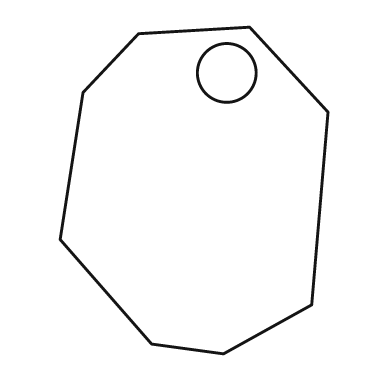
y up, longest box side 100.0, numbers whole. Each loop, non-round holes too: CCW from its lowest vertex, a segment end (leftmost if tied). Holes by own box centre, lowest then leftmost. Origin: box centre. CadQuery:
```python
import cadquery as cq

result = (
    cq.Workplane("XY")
    .moveTo(9.0, -50.0)
    .lineTo(36.0, -35.0)
    .lineTo(41.0, 24.0)
    .lineTo(17.0, 50.0)
    .lineTo(-17.0, 48.0)
    .lineTo(-34.0, 30.0)
    .lineTo(-41.0, -15.0)
    .lineTo(-13.0, -47.0)
    .close()
    .moveTo(10.0, 36.0)
    .circle(9.0)
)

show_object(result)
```